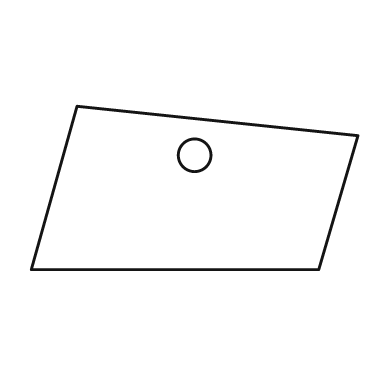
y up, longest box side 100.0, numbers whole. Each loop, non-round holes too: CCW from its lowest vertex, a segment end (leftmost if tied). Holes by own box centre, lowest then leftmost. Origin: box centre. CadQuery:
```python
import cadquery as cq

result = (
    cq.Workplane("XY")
    .moveTo(-50.0, -25.0)
    .lineTo(38.0, -25.0)
    .lineTo(50.0, 16.0)
    .lineTo(-36.0, 25.0)
    .close()
    .moveTo(0.0, 10.0)
    .circle(5.0)
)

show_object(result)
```